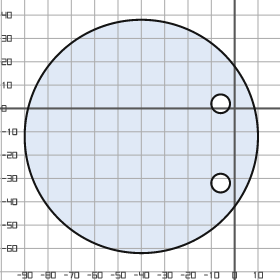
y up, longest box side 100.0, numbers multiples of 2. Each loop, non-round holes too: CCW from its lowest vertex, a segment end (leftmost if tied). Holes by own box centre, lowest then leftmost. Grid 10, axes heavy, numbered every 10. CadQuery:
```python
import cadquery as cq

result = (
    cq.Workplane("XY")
    .moveTo(-40.0, -12.0)
    .circle(50.0)
    .moveTo(-6.0, -32.0)
    .circle(4.0)
    .moveTo(-6.0, 2.0)
    .circle(4.0)
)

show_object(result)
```